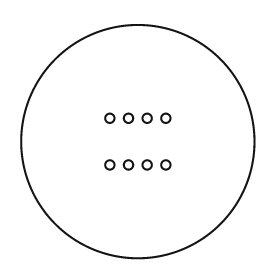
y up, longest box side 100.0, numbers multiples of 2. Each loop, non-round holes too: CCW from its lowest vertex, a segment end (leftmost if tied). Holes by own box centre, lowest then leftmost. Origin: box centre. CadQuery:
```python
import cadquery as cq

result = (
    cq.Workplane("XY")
    .moveTo(0.0, 0.0)
    .circle(50.0)
    .moveTo(-12.0, -10.0)
    .circle(2.0)
    .moveTo(-4.0, -10.0)
    .circle(2.0)
    .moveTo(4.0, -10.0)
    .circle(2.0)
    .moveTo(12.0, -10.0)
    .circle(2.0)
    .moveTo(-12.0, 10.0)
    .circle(2.0)
    .moveTo(-4.0, 10.0)
    .circle(2.0)
    .moveTo(4.0, 10.0)
    .circle(2.0)
    .moveTo(12.0, 10.0)
    .circle(2.0)
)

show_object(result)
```